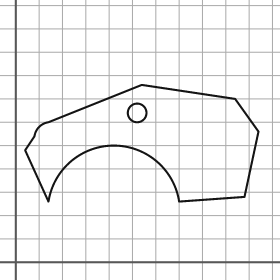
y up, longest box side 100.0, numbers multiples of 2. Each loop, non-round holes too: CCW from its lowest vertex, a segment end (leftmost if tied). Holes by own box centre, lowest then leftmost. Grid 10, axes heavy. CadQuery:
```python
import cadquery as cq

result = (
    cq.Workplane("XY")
    .moveTo(14.0, 26.0)
    .threePointArc((42.0, 50.0), (70.0, 26.0))
    .lineTo(98.0, 28.0)
    .lineTo(104.0, 56.0)
    .lineTo(94.0, 70.0)
    .lineTo(54.0, 76.0)
    .lineTo(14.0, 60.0)
    .threePointArc((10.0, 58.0), (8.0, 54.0))
    .lineTo(4.0, 48.0)
    .close()
    .moveTo(52.0, 64.0)
    .circle(4.0)
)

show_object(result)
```